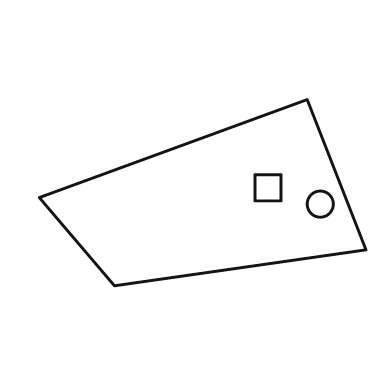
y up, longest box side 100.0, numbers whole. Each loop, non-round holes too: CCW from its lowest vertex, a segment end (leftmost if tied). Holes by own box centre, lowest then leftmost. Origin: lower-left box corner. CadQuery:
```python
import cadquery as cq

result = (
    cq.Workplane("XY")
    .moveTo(23.0, 0.0)
    .lineTo(100.0, 11.0)
    .lineTo(82.0, 57.0)
    .lineTo(0.0, 27.0)
    .close()
    .moveTo(86.0, 25.0)
    .circle(4.0)
    .moveTo(66.0, 26.0)
    .lineTo(74.0, 26.0)
    .lineTo(74.0, 34.0)
    .lineTo(66.0, 34.0)
    .close()
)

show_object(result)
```